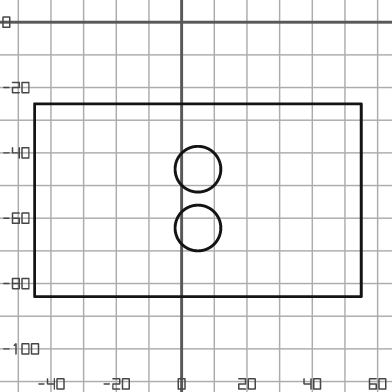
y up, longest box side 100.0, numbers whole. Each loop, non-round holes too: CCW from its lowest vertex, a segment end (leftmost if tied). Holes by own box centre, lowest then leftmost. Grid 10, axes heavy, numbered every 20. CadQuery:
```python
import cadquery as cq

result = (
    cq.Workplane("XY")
    .moveTo(-45.0, -84.0)
    .lineTo(55.0, -84.0)
    .lineTo(55.0, -25.0)
    .lineTo(-45.0, -25.0)
    .close()
    .moveTo(5.0, -63.0)
    .circle(7.0)
    .moveTo(5.0, -45.0)
    .circle(7.0)
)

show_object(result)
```